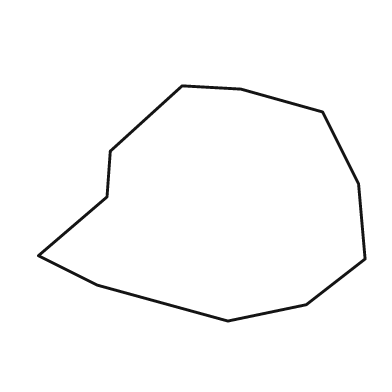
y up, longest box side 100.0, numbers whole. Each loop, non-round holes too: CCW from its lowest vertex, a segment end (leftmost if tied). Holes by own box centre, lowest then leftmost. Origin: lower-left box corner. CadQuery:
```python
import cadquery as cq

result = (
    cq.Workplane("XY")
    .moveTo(58.0, 0.0)
    .lineTo(82.0, 5.0)
    .lineTo(100.0, 19.0)
    .lineTo(98.0, 42.0)
    .lineTo(87.0, 64.0)
    .lineTo(62.0, 71.0)
    .lineTo(44.0, 72.0)
    .lineTo(22.0, 52.0)
    .lineTo(21.0, 38.0)
    .lineTo(0.0, 20.0)
    .lineTo(18.0, 11.0)
    .close()
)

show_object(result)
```